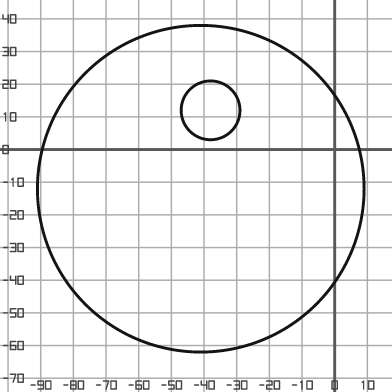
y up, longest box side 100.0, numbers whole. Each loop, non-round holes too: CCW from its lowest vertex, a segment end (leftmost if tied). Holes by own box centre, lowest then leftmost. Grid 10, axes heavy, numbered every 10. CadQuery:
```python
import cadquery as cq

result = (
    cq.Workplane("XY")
    .moveTo(-41.0, -12.0)
    .circle(50.0)
    .moveTo(-38.0, 12.0)
    .circle(9.0)
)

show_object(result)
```